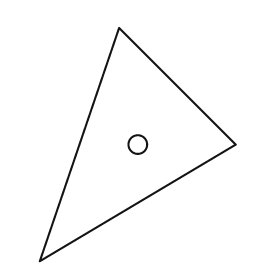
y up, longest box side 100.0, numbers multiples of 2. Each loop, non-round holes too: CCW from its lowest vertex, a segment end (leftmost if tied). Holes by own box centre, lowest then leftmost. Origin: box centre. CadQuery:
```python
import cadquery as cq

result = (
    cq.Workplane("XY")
    .moveTo(-42.0, -50.0)
    .lineTo(42.0, 0.0)
    .lineTo(-8.0, 50.0)
    .close()
    .moveTo(0.0, 0.0)
    .circle(4.0)
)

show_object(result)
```